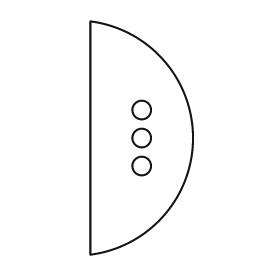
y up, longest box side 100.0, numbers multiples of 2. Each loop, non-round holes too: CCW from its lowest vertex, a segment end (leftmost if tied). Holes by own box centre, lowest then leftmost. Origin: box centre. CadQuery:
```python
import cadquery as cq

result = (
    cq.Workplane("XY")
    .moveTo(-22.0, -50.0)
    .threePointArc((22.0, 0.0), (-22.0, 50.0))
    .close()
    .moveTo(0.0, -12.0)
    .circle(4.0)
    .moveTo(0.0, 0.0)
    .circle(4.0)
    .moveTo(0.0, 12.0)
    .circle(4.0)
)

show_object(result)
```